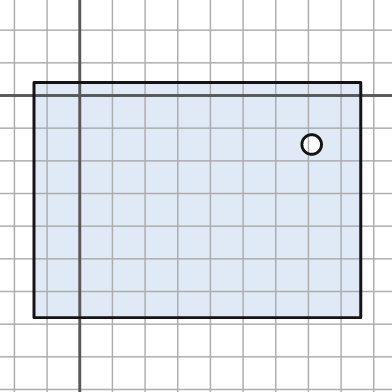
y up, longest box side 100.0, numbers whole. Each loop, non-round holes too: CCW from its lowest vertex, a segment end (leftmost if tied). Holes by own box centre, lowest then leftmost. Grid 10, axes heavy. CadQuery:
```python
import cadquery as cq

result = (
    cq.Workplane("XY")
    .moveTo(-14.0, -68.0)
    .lineTo(86.0, -68.0)
    .lineTo(86.0, 4.0)
    .lineTo(-14.0, 4.0)
    .close()
    .moveTo(71.0, -15.0)
    .circle(3.0)
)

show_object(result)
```